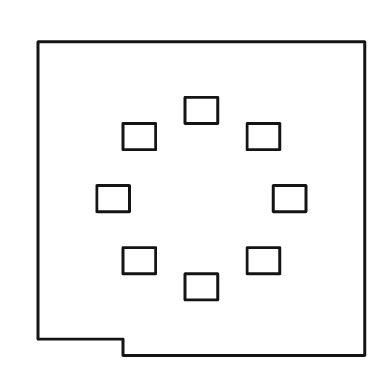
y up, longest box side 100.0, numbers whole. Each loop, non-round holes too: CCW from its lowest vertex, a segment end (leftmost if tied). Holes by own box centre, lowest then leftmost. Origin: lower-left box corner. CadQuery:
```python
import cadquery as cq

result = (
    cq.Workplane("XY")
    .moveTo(26.0, 0.0)
    .lineTo(100.0, 0.0)
    .lineTo(100.0, 96.0)
    .lineTo(0.0, 96.0)
    .lineTo(0.0, 5.0)
    .lineTo(26.0, 5.0)
    .close()
    .moveTo(45.0, 17.0)
    .lineTo(55.0, 17.0)
    .lineTo(55.0, 25.0)
    .lineTo(45.0, 25.0)
    .close()
    .moveTo(26.0, 25.0)
    .lineTo(36.0, 25.0)
    .lineTo(36.0, 33.0)
    .lineTo(26.0, 33.0)
    .close()
    .moveTo(64.0, 25.0)
    .lineTo(74.0, 25.0)
    .lineTo(74.0, 33.0)
    .lineTo(64.0, 33.0)
    .close()
    .moveTo(18.0, 44.0)
    .lineTo(28.0, 44.0)
    .lineTo(28.0, 52.0)
    .lineTo(18.0, 52.0)
    .close()
    .moveTo(72.0, 44.0)
    .lineTo(82.0, 44.0)
    .lineTo(82.0, 52.0)
    .lineTo(72.0, 52.0)
    .close()
    .moveTo(26.0, 63.0)
    .lineTo(36.0, 63.0)
    .lineTo(36.0, 71.0)
    .lineTo(26.0, 71.0)
    .close()
    .moveTo(64.0, 63.0)
    .lineTo(74.0, 63.0)
    .lineTo(74.0, 71.0)
    .lineTo(64.0, 71.0)
    .close()
    .moveTo(45.0, 71.0)
    .lineTo(55.0, 71.0)
    .lineTo(55.0, 79.0)
    .lineTo(45.0, 79.0)
    .close()
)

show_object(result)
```